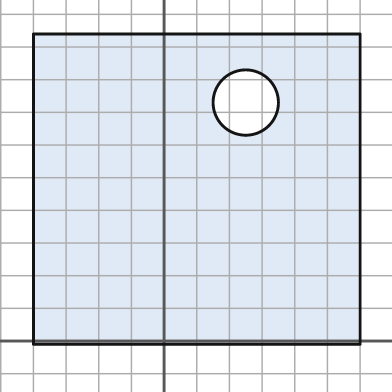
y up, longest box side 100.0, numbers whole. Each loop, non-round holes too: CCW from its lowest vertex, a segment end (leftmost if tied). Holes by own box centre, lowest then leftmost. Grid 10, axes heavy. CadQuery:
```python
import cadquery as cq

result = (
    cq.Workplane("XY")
    .moveTo(-40.0, -1.0)
    .lineTo(60.0, -1.0)
    .lineTo(60.0, 94.0)
    .lineTo(-40.0, 94.0)
    .close()
    .moveTo(25.0, 73.0)
    .circle(10.0)
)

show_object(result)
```